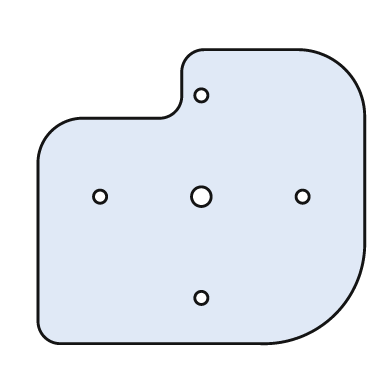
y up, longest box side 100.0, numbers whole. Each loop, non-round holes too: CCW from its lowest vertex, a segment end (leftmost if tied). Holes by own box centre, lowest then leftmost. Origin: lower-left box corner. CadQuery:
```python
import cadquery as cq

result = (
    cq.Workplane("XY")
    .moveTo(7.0, 0.0)
    .lineTo(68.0, 0.0)
    .threePointArc((91.0, 9.0), (100.0, 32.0))
    .lineTo(100.0, 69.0)
    .threePointArc((94.0, 84.0), (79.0, 90.0))
    .lineTo(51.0, 90.0)
    .threePointArc((46.0, 88.0), (44.0, 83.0))
    .lineTo(44.0, 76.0)
    .threePointArc((42.0, 71.0), (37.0, 69.0))
    .lineTo(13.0, 69.0)
    .threePointArc((4.0, 65.0), (0.0, 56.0))
    .lineTo(0.0, 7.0)
    .threePointArc((2.0, 2.0), (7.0, 0.0))
    .close()
    .moveTo(50.0, 14.0)
    .circle(2.0)
    .moveTo(19.0, 45.0)
    .circle(2.0)
    .moveTo(50.0, 45.0)
    .circle(3.0)
    .moveTo(81.0, 45.0)
    .circle(2.0)
    .moveTo(50.0, 76.0)
    .circle(2.0)
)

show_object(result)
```